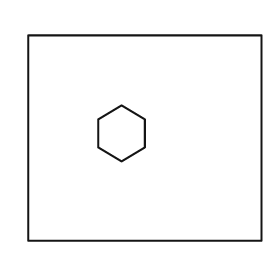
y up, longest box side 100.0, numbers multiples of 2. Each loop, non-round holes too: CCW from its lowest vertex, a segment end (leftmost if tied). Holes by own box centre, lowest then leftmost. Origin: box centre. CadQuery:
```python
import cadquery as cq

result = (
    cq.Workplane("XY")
    .moveTo(-50.0, -44.0)
    .lineTo(50.0, -44.0)
    .lineTo(50.0, 44.0)
    .lineTo(-50.0, 44.0)
    .close()
    .moveTo(-10.0, -10.0)
    .lineTo(0.0, -4.0)
    .lineTo(0.0, 8.0)
    .lineTo(-10.0, 14.0)
    .lineTo(-20.0, 8.0)
    .lineTo(-20.0, -4.0)
    .close()
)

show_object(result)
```